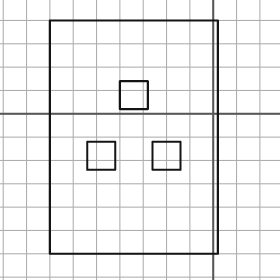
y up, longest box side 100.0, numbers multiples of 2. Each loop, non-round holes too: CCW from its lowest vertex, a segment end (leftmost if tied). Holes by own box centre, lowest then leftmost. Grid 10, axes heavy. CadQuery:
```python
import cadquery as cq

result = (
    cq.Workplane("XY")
    .moveTo(-70.0, -60.0)
    .lineTo(2.0, -60.0)
    .lineTo(2.0, 40.0)
    .lineTo(-70.0, 40.0)
    .close()
    .moveTo(-54.0, -24.0)
    .lineTo(-42.0, -24.0)
    .lineTo(-42.0, -12.0)
    .lineTo(-54.0, -12.0)
    .close()
    .moveTo(-26.0, -24.0)
    .lineTo(-14.0, -24.0)
    .lineTo(-14.0, -12.0)
    .lineTo(-26.0, -12.0)
    .close()
    .moveTo(-40.0, 2.0)
    .lineTo(-28.0, 2.0)
    .lineTo(-28.0, 14.0)
    .lineTo(-40.0, 14.0)
    .close()
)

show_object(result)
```